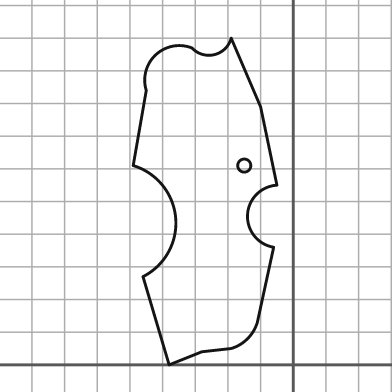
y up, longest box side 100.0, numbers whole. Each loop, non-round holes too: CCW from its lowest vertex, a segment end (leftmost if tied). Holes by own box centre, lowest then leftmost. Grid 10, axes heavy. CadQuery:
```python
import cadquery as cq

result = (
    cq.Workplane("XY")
    .moveTo(-38.0, 0.0)
    .lineTo(-28.0, 4.0)
    .lineTo(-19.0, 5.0)
    .threePointArc((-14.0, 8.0), (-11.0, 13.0))
    .lineTo(-6.0, 36.0)
    .threePointArc((-14.0, 46.0), (-5.0, 55.0))
    .lineTo(-10.0, 79.0)
    .lineTo(-19.0, 100.0)
    .threePointArc((-24.0, 95.0), (-31.0, 97.0))
    .threePointArc((-42.0, 95.0), (-45.0, 84.0))
    .lineTo(-49.0, 61.0)
    .threePointArc((-36.0, 45.0), (-46.0, 27.0))
    .close()
    .moveTo(-15.0, 61.0)
    .circle(2.0)
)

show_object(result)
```